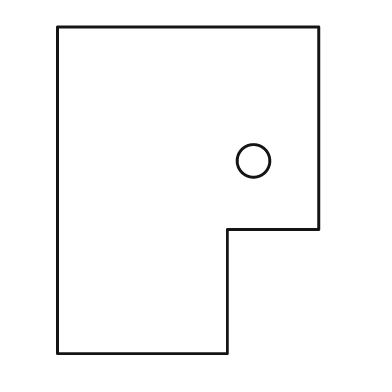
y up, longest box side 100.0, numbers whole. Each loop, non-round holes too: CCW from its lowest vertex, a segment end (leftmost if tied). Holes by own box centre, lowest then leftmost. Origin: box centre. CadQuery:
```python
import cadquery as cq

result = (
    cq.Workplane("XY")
    .moveTo(-40.0, -50.0)
    .lineTo(12.0, -50.0)
    .lineTo(12.0, -12.0)
    .lineTo(40.0, -12.0)
    .lineTo(40.0, 50.0)
    .lineTo(-40.0, 50.0)
    .close()
    .moveTo(20.0, 9.0)
    .circle(5.0)
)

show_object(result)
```